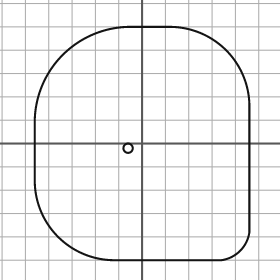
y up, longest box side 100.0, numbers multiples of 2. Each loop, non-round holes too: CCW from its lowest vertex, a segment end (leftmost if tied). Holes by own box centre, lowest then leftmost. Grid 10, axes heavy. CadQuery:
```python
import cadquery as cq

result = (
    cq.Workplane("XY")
    .moveTo(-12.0, -50.0)
    .lineTo(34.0, -50.0)
    .threePointArc((42.0, -46.0), (46.0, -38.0))
    .lineTo(46.0, 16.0)
    .threePointArc((36.0, 40.0), (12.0, 50.0))
    .lineTo(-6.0, 50.0)
    .threePointArc((-34.0, 38.0), (-46.0, 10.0))
    .lineTo(-46.0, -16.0)
    .threePointArc((-36.0, -40.0), (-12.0, -50.0))
    .close()
    .moveTo(-6.0, -2.0)
    .circle(2.0)
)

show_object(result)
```